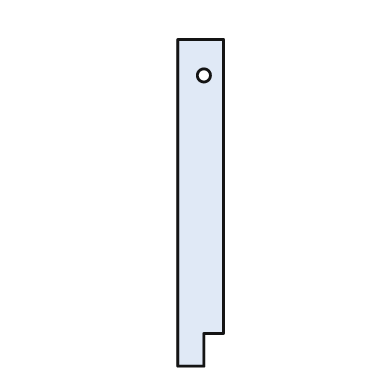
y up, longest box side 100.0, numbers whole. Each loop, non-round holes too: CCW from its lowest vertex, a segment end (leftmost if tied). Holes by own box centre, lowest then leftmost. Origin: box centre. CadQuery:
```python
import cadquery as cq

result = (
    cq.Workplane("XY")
    .moveTo(-7.0, -50.0)
    .lineTo(1.0, -50.0)
    .lineTo(1.0, -40.0)
    .lineTo(7.0, -40.0)
    .lineTo(7.0, 50.0)
    .lineTo(-7.0, 50.0)
    .close()
    .moveTo(1.0, 39.0)
    .circle(2.0)
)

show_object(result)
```